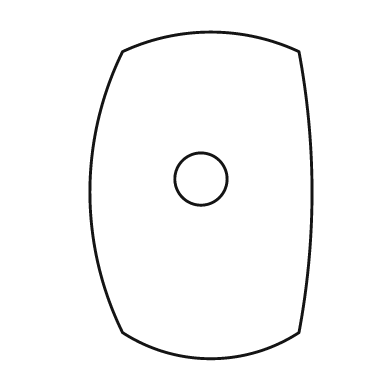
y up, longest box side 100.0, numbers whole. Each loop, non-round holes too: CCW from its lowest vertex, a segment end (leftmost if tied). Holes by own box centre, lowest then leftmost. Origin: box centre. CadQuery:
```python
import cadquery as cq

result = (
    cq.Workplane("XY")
    .moveTo(-24.0, -42.0)
    .threePointArc((3.0, -50.0), (30.0, -42.0))
    .threePointArc((34.0, 1.0), (30.0, 44.0))
    .threePointArc((3.0, 50.0), (-24.0, 44.0))
    .threePointArc((-34.0, 1.0), (-24.0, -42.0))
    .close()
    .moveTo(0.0, 5.0)
    .circle(8.0)
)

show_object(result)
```